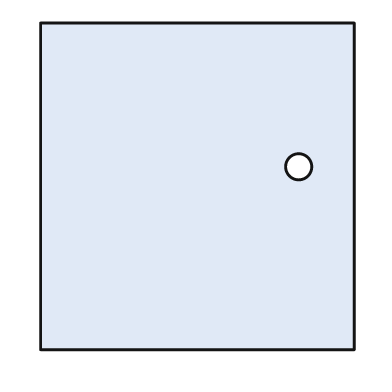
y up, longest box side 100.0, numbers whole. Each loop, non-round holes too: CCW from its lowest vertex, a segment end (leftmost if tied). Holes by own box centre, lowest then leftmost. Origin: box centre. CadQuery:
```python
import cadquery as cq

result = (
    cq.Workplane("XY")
    .moveTo(-48.0, -50.0)
    .lineTo(48.0, -50.0)
    .lineTo(48.0, 50.0)
    .lineTo(-48.0, 50.0)
    .close()
    .moveTo(31.0, 6.0)
    .circle(4.0)
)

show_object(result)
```